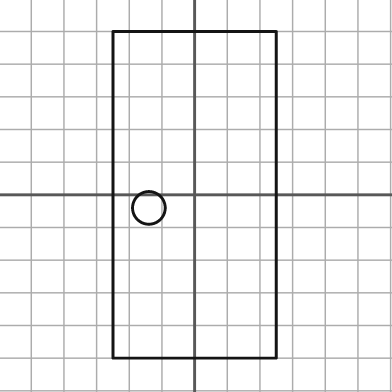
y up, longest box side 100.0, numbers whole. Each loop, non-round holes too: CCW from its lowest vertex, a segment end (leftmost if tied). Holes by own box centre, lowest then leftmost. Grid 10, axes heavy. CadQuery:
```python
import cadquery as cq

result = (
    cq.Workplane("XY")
    .moveTo(-25.0, -50.0)
    .lineTo(25.0, -50.0)
    .lineTo(25.0, 50.0)
    .lineTo(-25.0, 50.0)
    .close()
    .moveTo(-14.0, -4.0)
    .circle(5.0)
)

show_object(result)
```